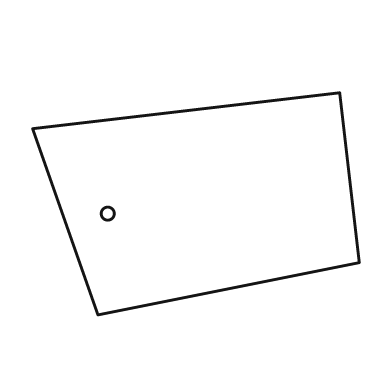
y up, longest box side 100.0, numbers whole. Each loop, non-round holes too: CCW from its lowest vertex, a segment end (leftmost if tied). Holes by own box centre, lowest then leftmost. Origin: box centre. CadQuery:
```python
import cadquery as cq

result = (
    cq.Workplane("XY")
    .moveTo(-30.0, -34.0)
    .lineTo(50.0, -18.0)
    .lineTo(44.0, 34.0)
    .lineTo(-50.0, 23.0)
    .close()
    .moveTo(-27.0, -3.0)
    .circle(2.0)
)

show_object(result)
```